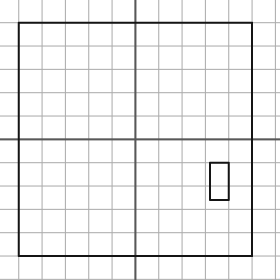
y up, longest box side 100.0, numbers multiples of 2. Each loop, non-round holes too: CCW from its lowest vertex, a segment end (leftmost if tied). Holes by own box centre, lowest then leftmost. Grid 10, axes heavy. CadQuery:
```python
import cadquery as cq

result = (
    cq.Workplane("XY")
    .moveTo(-50.0, -50.0)
    .lineTo(50.0, -50.0)
    .lineTo(50.0, 50.0)
    .lineTo(-50.0, 50.0)
    .close()
    .moveTo(32.0, -26.0)
    .lineTo(40.0, -26.0)
    .lineTo(40.0, -10.0)
    .lineTo(32.0, -10.0)
    .close()
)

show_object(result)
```